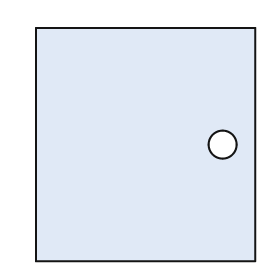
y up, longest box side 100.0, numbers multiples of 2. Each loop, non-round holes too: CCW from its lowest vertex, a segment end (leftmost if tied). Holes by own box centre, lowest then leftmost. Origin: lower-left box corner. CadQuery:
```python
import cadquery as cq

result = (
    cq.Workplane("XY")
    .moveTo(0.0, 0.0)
    .lineTo(94.0, 0.0)
    .lineTo(94.0, 100.0)
    .lineTo(0.0, 100.0)
    .close()
    .moveTo(80.0, 50.0)
    .circle(6.0)
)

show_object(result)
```